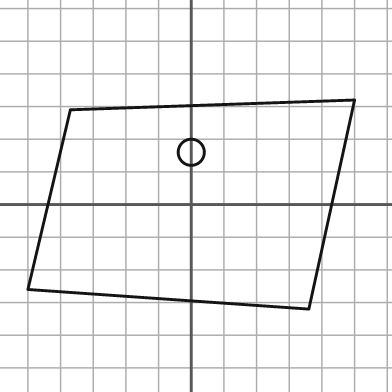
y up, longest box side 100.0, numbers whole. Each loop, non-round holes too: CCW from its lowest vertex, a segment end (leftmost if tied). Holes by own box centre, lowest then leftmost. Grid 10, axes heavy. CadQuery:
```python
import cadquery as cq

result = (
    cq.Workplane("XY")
    .moveTo(36.0, -32.0)
    .lineTo(50.0, 32.0)
    .lineTo(-37.0, 29.0)
    .lineTo(-50.0, -26.0)
    .close()
    .moveTo(0.0, 16.0)
    .circle(4.0)
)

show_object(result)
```